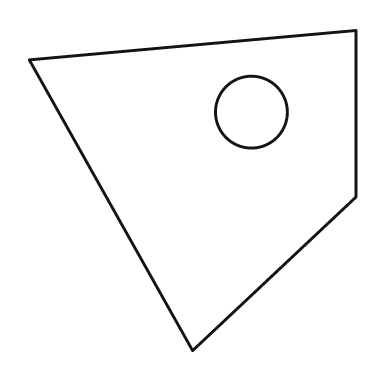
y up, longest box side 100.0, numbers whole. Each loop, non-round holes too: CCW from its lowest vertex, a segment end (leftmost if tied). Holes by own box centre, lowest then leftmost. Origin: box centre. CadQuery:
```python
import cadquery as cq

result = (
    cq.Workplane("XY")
    .moveTo(0.0, -49.0)
    .lineTo(50.0, -2.0)
    .lineTo(50.0, 49.0)
    .lineTo(-50.0, 40.0)
    .close()
    .moveTo(18.0, 24.0)
    .circle(11.0)
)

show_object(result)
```